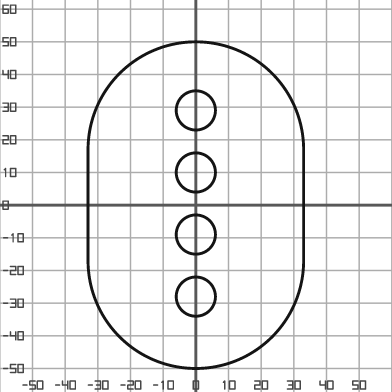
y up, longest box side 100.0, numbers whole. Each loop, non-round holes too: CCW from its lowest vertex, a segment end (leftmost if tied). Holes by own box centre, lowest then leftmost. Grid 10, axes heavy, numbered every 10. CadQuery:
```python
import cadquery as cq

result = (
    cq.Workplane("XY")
    .moveTo(-33.0, -17.0)
    .threePointArc((0.0, -50.0), (33.0, -17.0))
    .lineTo(33.0, 17.0)
    .threePointArc((0.0, 50.0), (-33.0, 17.0))
    .close()
    .moveTo(0.0, -28.0)
    .circle(6.0)
    .moveTo(0.0, -9.0)
    .circle(6.0)
    .moveTo(0.0, 10.0)
    .circle(6.0)
    .moveTo(0.0, 29.0)
    .circle(6.0)
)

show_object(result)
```